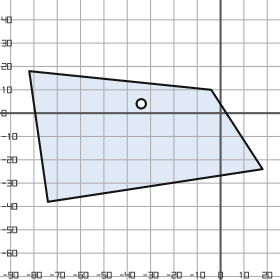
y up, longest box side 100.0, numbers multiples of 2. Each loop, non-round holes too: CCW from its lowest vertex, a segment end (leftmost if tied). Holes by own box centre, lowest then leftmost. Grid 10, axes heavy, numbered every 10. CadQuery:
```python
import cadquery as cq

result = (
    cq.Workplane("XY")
    .moveTo(-74.0, -38.0)
    .lineTo(18.0, -24.0)
    .lineTo(-4.0, 10.0)
    .lineTo(-82.0, 18.0)
    .close()
    .moveTo(-34.0, 4.0)
    .circle(2.0)
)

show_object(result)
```